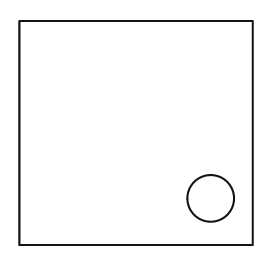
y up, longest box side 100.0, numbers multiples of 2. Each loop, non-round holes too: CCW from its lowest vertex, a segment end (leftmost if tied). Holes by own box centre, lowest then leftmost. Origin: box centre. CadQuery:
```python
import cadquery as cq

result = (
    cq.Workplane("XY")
    .moveTo(-50.0, -48.0)
    .lineTo(50.0, -48.0)
    .lineTo(50.0, 48.0)
    .lineTo(-50.0, 48.0)
    .close()
    .moveTo(32.0, -28.0)
    .circle(10.0)
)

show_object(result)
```